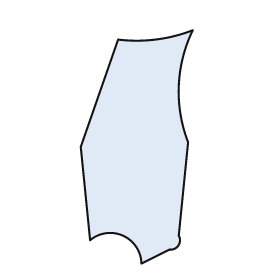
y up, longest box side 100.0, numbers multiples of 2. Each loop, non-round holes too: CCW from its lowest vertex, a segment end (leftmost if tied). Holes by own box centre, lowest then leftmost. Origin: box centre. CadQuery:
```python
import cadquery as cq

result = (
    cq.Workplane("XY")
    .moveTo(2.0, -50.0)
    .lineTo(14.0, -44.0)
    .threePointArc((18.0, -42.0), (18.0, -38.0))
    .lineTo(22.0, 2.0)
    .threePointArc((18.0, 26.0), (24.0, 50.0))
    .threePointArc((8.0, 46.0), (-8.0, 46.0))
    .lineTo(-24.0, 0.0)
    .lineTo(-20.0, -40.0)
    .threePointArc((-6.0, -38.0), (2.0, -50.0))
    .close()
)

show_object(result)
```